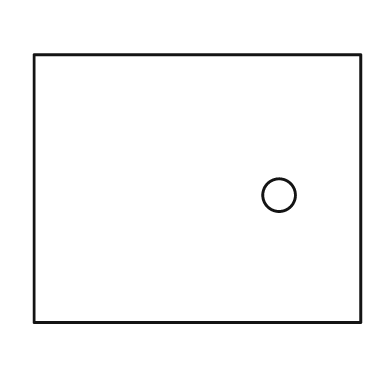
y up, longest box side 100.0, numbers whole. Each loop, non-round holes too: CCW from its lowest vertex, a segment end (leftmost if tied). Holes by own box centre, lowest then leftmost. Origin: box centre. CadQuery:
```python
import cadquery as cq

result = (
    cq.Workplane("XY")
    .moveTo(-50.0, -41.0)
    .lineTo(50.0, -41.0)
    .lineTo(50.0, 41.0)
    .lineTo(-50.0, 41.0)
    .close()
    .moveTo(25.0, -2.0)
    .circle(5.0)
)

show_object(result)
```